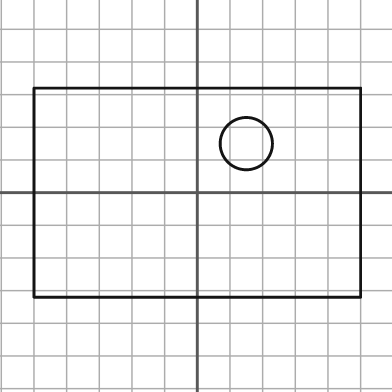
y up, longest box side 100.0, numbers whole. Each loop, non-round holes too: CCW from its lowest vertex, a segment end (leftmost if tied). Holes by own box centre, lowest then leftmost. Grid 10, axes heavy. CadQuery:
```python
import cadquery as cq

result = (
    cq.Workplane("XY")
    .moveTo(-50.0, -32.0)
    .lineTo(50.0, -32.0)
    .lineTo(50.0, 32.0)
    .lineTo(-50.0, 32.0)
    .close()
    .moveTo(15.0, 15.0)
    .circle(8.0)
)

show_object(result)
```